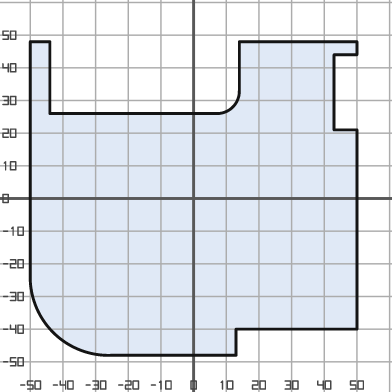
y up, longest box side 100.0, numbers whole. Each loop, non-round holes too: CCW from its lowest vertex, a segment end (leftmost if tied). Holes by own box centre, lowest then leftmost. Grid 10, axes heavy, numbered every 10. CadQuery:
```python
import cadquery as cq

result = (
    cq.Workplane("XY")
    .moveTo(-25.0, -48.0)
    .lineTo(13.0, -48.0)
    .lineTo(13.0, -40.0)
    .lineTo(50.0, -40.0)
    .lineTo(50.0, 21.0)
    .lineTo(43.0, 21.0)
    .lineTo(43.0, 44.0)
    .lineTo(50.0, 44.0)
    .lineTo(50.0, 48.0)
    .lineTo(14.0, 48.0)
    .lineTo(14.0, 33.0)
    .threePointArc((12.0, 28.0), (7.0, 26.0))
    .lineTo(-44.0, 26.0)
    .lineTo(-44.0, 48.0)
    .lineTo(-50.0, 48.0)
    .lineTo(-50.0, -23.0)
    .threePointArc((-43.0, -41.0), (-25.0, -48.0))
    .close()
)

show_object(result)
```